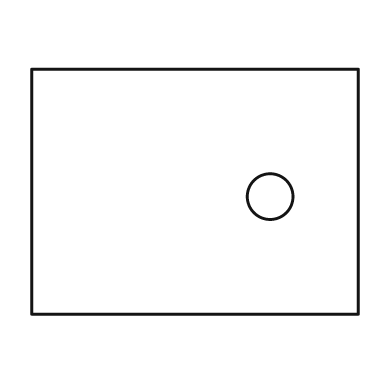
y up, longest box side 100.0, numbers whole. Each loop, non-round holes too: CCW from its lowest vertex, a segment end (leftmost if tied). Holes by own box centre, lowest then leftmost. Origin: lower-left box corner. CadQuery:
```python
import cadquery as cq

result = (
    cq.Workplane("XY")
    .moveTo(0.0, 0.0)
    .lineTo(100.0, 0.0)
    .lineTo(100.0, 75.0)
    .lineTo(0.0, 75.0)
    .close()
    .moveTo(73.0, 36.0)
    .circle(7.0)
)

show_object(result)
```